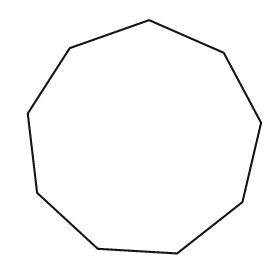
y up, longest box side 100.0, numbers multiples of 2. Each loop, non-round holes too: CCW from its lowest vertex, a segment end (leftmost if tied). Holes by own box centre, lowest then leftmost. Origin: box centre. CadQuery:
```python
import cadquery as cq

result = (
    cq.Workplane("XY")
    .moveTo(14.0, -50.0)
    .lineTo(42.0, -28.0)
    .lineTo(50.0, 6.0)
    .lineTo(34.0, 36.0)
    .lineTo(2.0, 50.0)
    .lineTo(-32.0, 38.0)
    .lineTo(-50.0, 10.0)
    .lineTo(-46.0, -24.0)
    .lineTo(-20.0, -48.0)
    .close()
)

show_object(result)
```